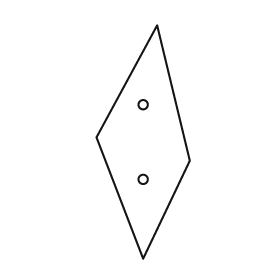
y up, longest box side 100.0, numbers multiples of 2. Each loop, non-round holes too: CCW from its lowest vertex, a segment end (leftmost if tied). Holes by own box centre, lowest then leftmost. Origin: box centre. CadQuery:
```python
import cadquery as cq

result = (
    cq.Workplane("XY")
    .moveTo(0.0, -50.0)
    .lineTo(20.0, -8.0)
    .lineTo(6.0, 50.0)
    .lineTo(-20.0, 2.0)
    .close()
    .moveTo(0.0, -16.0)
    .circle(2.0)
    .moveTo(0.0, 16.0)
    .circle(2.0)
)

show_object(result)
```